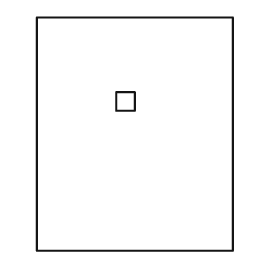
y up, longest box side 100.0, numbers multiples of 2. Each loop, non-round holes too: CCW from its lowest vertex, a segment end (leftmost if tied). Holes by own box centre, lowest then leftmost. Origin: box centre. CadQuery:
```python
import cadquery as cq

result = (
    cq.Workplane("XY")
    .moveTo(-42.0, -50.0)
    .lineTo(42.0, -50.0)
    .lineTo(42.0, 50.0)
    .lineTo(-42.0, 50.0)
    .close()
    .moveTo(-8.0, 10.0)
    .lineTo(0.0, 10.0)
    .lineTo(0.0, 18.0)
    .lineTo(-8.0, 18.0)
    .close()
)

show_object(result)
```